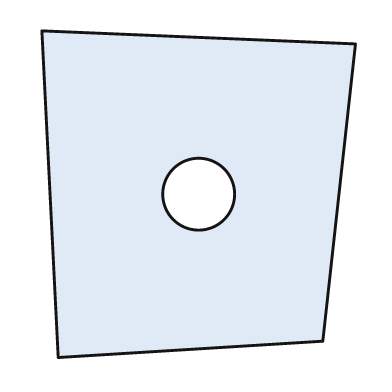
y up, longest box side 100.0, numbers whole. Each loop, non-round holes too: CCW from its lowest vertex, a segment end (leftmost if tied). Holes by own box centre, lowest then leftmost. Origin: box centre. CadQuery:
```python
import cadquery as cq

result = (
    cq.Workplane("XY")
    .moveTo(-43.0, -50.0)
    .lineTo(38.0, -45.0)
    .lineTo(48.0, 46.0)
    .lineTo(-48.0, 50.0)
    .close()
    .moveTo(0.0, 0.0)
    .circle(11.0)
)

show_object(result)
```